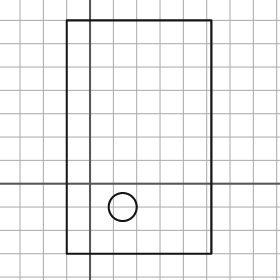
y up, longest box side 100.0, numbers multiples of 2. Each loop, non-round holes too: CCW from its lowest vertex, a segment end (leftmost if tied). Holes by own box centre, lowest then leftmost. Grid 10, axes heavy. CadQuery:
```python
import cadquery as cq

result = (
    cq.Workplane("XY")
    .moveTo(-10.0, -30.0)
    .lineTo(52.0, -30.0)
    .lineTo(52.0, 70.0)
    .lineTo(-10.0, 70.0)
    .close()
    .moveTo(14.0, -10.0)
    .circle(6.0)
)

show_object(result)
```